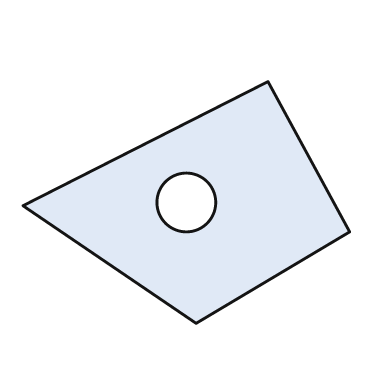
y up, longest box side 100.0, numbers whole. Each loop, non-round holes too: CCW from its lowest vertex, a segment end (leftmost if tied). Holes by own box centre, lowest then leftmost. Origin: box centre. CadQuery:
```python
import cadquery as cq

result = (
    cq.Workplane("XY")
    .moveTo(3.0, -37.0)
    .lineTo(50.0, -9.0)
    .lineTo(25.0, 37.0)
    .lineTo(-50.0, -1.0)
    .close()
    .moveTo(0.0, 0.0)
    .circle(9.0)
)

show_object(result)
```